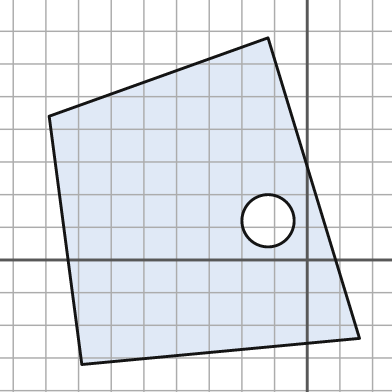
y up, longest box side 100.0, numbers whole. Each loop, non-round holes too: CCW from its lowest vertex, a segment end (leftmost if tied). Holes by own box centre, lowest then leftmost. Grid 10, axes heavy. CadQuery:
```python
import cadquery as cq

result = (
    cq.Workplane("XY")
    .moveTo(-69.0, -32.0)
    .lineTo(16.0, -24.0)
    .lineTo(-12.0, 68.0)
    .lineTo(-79.0, 44.0)
    .close()
    .moveTo(-12.0, 12.0)
    .circle(8.0)
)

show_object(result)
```